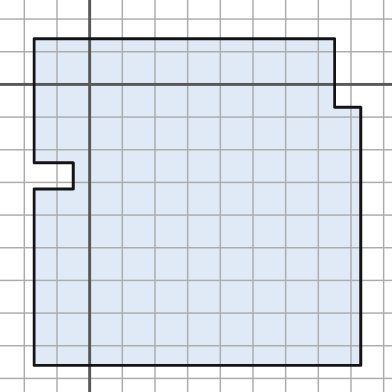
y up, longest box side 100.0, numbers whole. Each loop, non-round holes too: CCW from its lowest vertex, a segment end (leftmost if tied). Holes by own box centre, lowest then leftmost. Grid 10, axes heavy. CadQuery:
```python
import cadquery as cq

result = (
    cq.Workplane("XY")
    .moveTo(-17.0, -86.0)
    .lineTo(83.0, -86.0)
    .lineTo(83.0, -7.0)
    .lineTo(75.0, -7.0)
    .lineTo(75.0, 14.0)
    .lineTo(-17.0, 14.0)
    .lineTo(-17.0, -24.0)
    .lineTo(-5.0, -24.0)
    .lineTo(-5.0, -32.0)
    .lineTo(-17.0, -32.0)
    .close()
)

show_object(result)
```